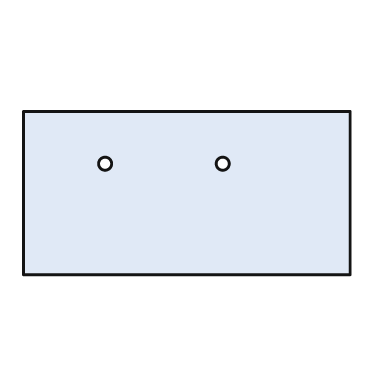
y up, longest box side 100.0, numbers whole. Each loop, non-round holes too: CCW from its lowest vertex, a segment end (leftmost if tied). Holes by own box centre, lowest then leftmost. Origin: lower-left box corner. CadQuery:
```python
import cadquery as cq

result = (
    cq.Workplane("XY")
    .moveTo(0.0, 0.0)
    .lineTo(100.0, 0.0)
    .lineTo(100.0, 50.0)
    .lineTo(0.0, 50.0)
    .close()
    .moveTo(25.0, 34.0)
    .circle(2.0)
    .moveTo(61.0, 34.0)
    .circle(2.0)
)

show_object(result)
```